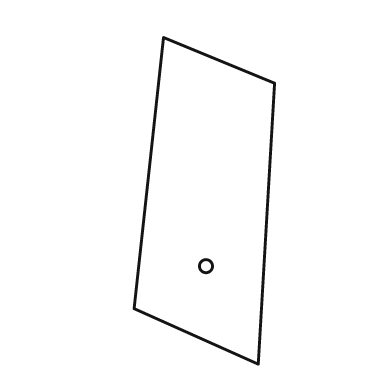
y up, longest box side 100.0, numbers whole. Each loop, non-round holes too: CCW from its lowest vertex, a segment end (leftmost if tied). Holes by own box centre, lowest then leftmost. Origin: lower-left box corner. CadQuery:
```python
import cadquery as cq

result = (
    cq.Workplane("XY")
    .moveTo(38.0, 0.0)
    .lineTo(43.0, 86.0)
    .lineTo(9.0, 100.0)
    .lineTo(0.0, 17.0)
    .close()
    .moveTo(22.0, 30.0)
    .circle(2.0)
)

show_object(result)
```